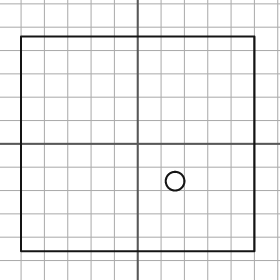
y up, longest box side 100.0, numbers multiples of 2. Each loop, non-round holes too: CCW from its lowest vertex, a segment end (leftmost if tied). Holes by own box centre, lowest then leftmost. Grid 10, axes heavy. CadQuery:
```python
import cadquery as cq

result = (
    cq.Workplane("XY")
    .moveTo(-50.0, -46.0)
    .lineTo(50.0, -46.0)
    .lineTo(50.0, 46.0)
    .lineTo(-50.0, 46.0)
    .close()
    .moveTo(16.0, -16.0)
    .circle(4.0)
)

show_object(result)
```